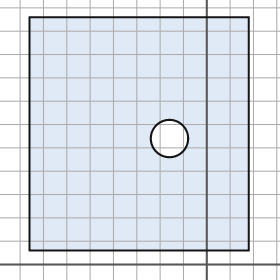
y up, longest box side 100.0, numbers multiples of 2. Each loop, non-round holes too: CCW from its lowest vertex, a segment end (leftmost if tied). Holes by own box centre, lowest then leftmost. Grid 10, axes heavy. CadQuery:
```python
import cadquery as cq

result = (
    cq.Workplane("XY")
    .moveTo(-76.0, 6.0)
    .lineTo(18.0, 6.0)
    .lineTo(18.0, 106.0)
    .lineTo(-76.0, 106.0)
    .close()
    .moveTo(-16.0, 54.0)
    .circle(8.0)
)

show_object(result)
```